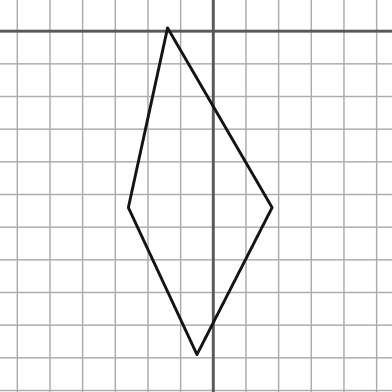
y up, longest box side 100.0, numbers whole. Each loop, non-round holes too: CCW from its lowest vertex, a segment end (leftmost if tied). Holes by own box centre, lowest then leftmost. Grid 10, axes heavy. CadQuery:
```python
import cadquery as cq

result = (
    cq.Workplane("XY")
    .moveTo(-5.0, -99.0)
    .lineTo(18.0, -54.0)
    .lineTo(-14.0, 1.0)
    .lineTo(-26.0, -54.0)
    .close()
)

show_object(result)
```